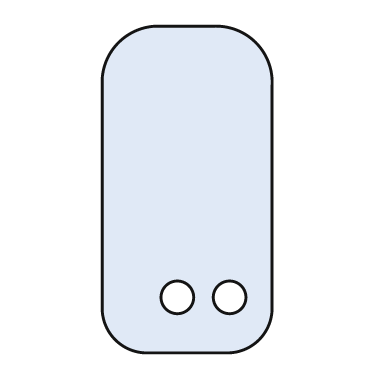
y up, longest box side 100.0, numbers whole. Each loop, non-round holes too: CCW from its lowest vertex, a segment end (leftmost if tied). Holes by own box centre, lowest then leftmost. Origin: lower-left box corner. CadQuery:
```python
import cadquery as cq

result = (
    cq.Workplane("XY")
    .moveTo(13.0, 0.0)
    .lineTo(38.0, 0.0)
    .threePointArc((48.0, 4.0), (52.0, 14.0))
    .lineTo(52.0, 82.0)
    .threePointArc((47.0, 95.0), (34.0, 100.0))
    .lineTo(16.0, 100.0)
    .threePointArc((5.0, 95.0), (0.0, 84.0))
    .lineTo(0.0, 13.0)
    .threePointArc((4.0, 4.0), (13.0, 0.0))
    .close()
    .moveTo(23.0, 17.0)
    .circle(5.0)
    .moveTo(39.0, 17.0)
    .circle(5.0)
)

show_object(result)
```